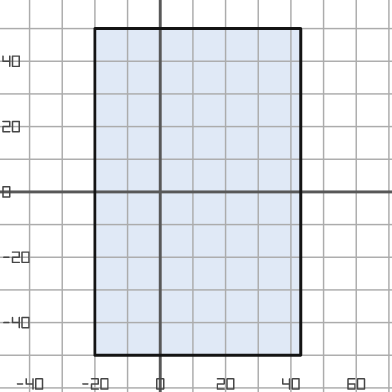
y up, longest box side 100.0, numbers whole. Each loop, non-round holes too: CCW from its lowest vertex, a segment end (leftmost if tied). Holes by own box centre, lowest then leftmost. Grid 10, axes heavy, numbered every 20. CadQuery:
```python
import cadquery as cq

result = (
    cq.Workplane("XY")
    .moveTo(-20.0, -50.0)
    .lineTo(43.0, -50.0)
    .lineTo(43.0, 50.0)
    .lineTo(-20.0, 50.0)
    .close()
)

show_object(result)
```